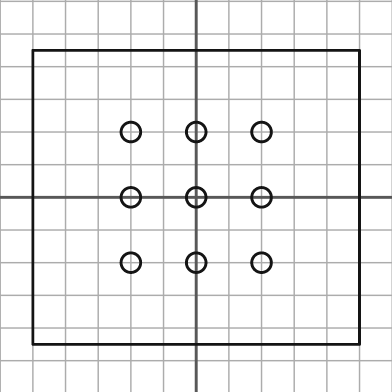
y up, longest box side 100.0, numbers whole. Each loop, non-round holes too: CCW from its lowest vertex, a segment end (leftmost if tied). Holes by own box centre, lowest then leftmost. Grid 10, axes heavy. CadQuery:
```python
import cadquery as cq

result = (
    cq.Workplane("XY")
    .moveTo(-50.0, -45.0)
    .lineTo(50.0, -45.0)
    .lineTo(50.0, 45.0)
    .lineTo(-50.0, 45.0)
    .close()
    .moveTo(-20.0, -20.0)
    .circle(3.0)
    .moveTo(0.0, -20.0)
    .circle(3.0)
    .moveTo(20.0, -20.0)
    .circle(3.0)
    .moveTo(-20.0, 0.0)
    .circle(3.0)
    .moveTo(0.0, 0.0)
    .circle(3.0)
    .moveTo(20.0, 0.0)
    .circle(3.0)
    .moveTo(-20.0, 20.0)
    .circle(3.0)
    .moveTo(0.0, 20.0)
    .circle(3.0)
    .moveTo(20.0, 20.0)
    .circle(3.0)
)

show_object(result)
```